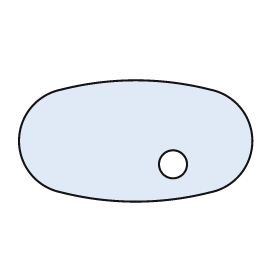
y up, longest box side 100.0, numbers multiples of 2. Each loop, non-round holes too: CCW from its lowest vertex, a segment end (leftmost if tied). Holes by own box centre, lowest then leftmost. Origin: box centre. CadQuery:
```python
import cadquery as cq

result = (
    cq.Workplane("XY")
    .moveTo(-32.0, -22.0)
    .threePointArc((0.0, -26.0), (32.0, -22.0))
    .threePointArc((50.0, 0.0), (32.0, 22.0))
    .threePointArc((0.0, 26.0), (-32.0, 22.0))
    .threePointArc((-50.0, 0.0), (-32.0, -22.0))
    .close()
    .moveTo(16.0, -10.0)
    .circle(6.0)
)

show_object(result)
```